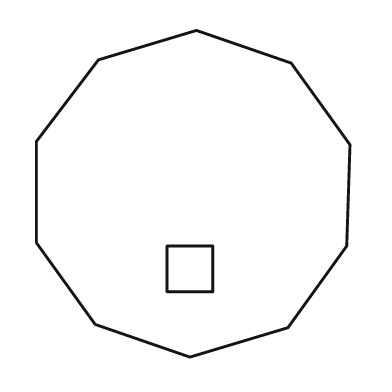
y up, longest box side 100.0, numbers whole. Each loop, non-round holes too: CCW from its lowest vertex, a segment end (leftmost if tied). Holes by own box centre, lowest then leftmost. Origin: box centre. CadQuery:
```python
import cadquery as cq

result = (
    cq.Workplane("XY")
    .moveTo(-1.0, -50.0)
    .lineTo(29.0, -41.0)
    .lineTo(47.0, -16.0)
    .lineTo(48.0, 15.0)
    .lineTo(30.0, 40.0)
    .lineTo(1.0, 50.0)
    .lineTo(-29.0, 41.0)
    .lineTo(-48.0, 16.0)
    .lineTo(-48.0, -15.0)
    .lineTo(-30.0, -40.0)
    .close()
    .moveTo(-8.0, -30.0)
    .lineTo(6.0, -30.0)
    .lineTo(6.0, -16.0)
    .lineTo(-8.0, -16.0)
    .close()
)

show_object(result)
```